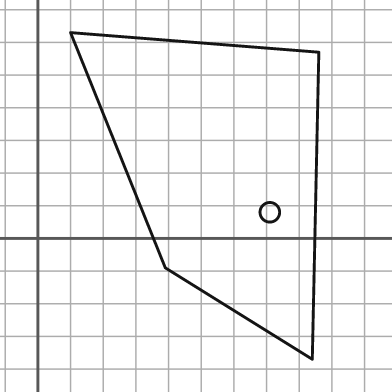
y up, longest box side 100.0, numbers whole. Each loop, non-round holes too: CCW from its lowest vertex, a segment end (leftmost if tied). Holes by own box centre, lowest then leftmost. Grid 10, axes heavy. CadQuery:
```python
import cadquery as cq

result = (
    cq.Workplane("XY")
    .moveTo(84.0, -37.0)
    .lineTo(86.0, 57.0)
    .lineTo(10.0, 63.0)
    .lineTo(39.0, -9.0)
    .close()
    .moveTo(71.0, 8.0)
    .circle(3.0)
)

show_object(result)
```